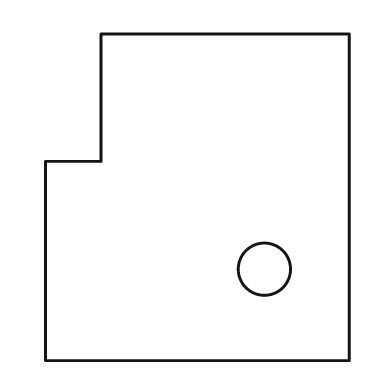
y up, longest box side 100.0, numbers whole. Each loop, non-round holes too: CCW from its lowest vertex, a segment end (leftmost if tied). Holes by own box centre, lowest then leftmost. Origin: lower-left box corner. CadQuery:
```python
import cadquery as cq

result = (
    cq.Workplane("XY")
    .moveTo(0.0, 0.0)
    .lineTo(93.0, 0.0)
    .lineTo(93.0, 100.0)
    .lineTo(17.0, 100.0)
    .lineTo(17.0, 61.0)
    .lineTo(0.0, 61.0)
    .close()
    .moveTo(67.0, 28.0)
    .circle(8.0)
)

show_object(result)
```